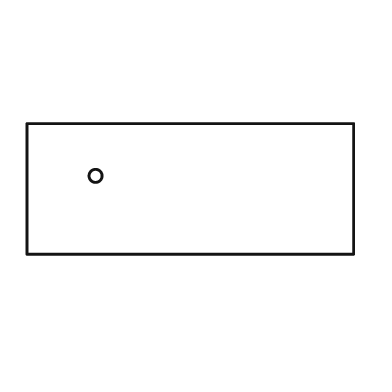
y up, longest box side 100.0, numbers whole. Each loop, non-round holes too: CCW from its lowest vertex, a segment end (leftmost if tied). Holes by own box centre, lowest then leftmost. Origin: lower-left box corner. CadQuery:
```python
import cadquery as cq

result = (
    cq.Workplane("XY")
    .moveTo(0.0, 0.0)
    .lineTo(100.0, 0.0)
    .lineTo(100.0, 40.0)
    .lineTo(0.0, 40.0)
    .close()
    .moveTo(21.0, 24.0)
    .circle(2.0)
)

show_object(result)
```